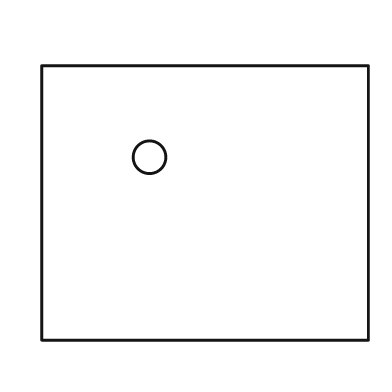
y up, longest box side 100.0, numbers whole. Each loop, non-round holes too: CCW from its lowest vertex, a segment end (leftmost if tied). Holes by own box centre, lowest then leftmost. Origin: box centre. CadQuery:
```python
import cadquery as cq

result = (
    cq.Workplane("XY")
    .moveTo(-50.0, -42.0)
    .lineTo(50.0, -42.0)
    .lineTo(50.0, 42.0)
    .lineTo(-50.0, 42.0)
    .close()
    .moveTo(-17.0, 14.0)
    .circle(5.0)
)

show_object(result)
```